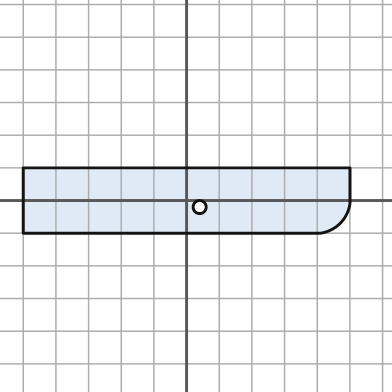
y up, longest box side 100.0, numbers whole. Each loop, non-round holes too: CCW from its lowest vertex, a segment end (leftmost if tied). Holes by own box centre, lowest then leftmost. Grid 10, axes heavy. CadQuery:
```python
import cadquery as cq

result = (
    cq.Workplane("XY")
    .moveTo(-50.0, -10.0)
    .lineTo(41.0, -10.0)
    .threePointArc((47.0, -7.0), (50.0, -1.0))
    .lineTo(50.0, 10.0)
    .lineTo(-50.0, 10.0)
    .close()
    .moveTo(4.0, -2.0)
    .circle(2.0)
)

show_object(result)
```